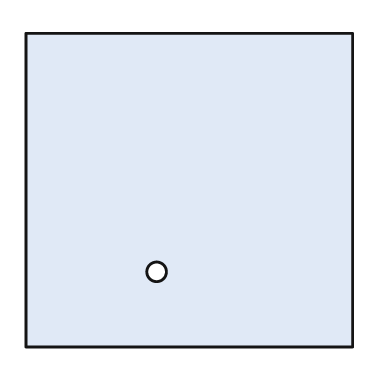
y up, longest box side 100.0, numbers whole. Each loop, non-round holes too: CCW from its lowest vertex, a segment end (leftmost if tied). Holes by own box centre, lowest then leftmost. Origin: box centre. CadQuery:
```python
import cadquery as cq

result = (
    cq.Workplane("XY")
    .moveTo(-50.0, -48.0)
    .lineTo(50.0, -48.0)
    .lineTo(50.0, 48.0)
    .lineTo(-50.0, 48.0)
    .close()
    .moveTo(-10.0, -25.0)
    .circle(3.0)
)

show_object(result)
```